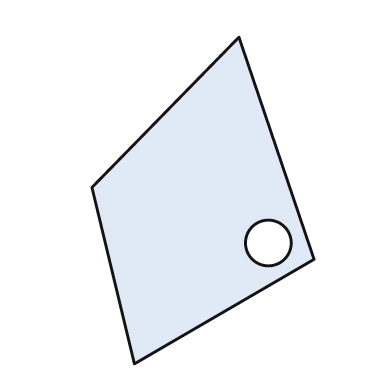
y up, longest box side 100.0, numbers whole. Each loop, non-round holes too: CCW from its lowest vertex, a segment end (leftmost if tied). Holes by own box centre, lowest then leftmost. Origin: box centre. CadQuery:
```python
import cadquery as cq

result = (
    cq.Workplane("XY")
    .moveTo(-21.0, -50.0)
    .lineTo(34.0, -18.0)
    .lineTo(11.0, 50.0)
    .lineTo(-34.0, 4.0)
    .close()
    .moveTo(20.0, -13.0)
    .circle(7.0)
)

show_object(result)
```